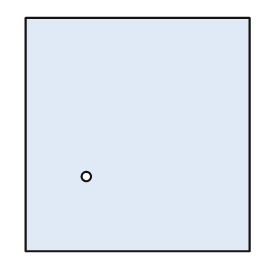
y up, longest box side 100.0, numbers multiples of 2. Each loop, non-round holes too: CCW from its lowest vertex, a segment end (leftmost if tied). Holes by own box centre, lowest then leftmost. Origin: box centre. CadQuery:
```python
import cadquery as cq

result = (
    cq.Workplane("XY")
    .moveTo(-48.0, -50.0)
    .lineTo(48.0, -50.0)
    .lineTo(48.0, 50.0)
    .lineTo(-48.0, 50.0)
    .close()
    .moveTo(-22.0, -18.0)
    .circle(2.0)
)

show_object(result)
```